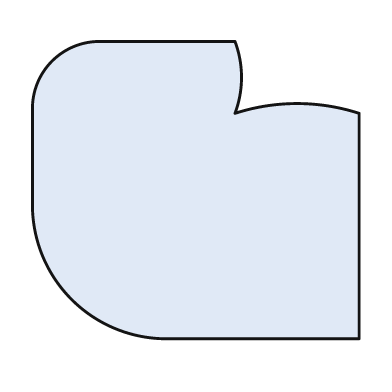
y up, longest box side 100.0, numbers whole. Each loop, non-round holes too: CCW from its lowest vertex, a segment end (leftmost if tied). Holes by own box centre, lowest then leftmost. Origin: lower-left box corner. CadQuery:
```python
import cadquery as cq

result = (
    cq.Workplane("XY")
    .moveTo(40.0, 0.0)
    .lineTo(100.0, 0.0)
    .lineTo(100.0, 69.0)
    .threePointArc((81.0, 72.0), (62.0, 69.0))
    .threePointArc((64.0, 80.0), (62.0, 91.0))
    .lineTo(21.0, 91.0)
    .threePointArc((6.0, 85.0), (0.0, 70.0))
    .lineTo(0.0, 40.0)
    .threePointArc((12.0, 12.0), (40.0, 0.0))
    .close()
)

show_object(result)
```